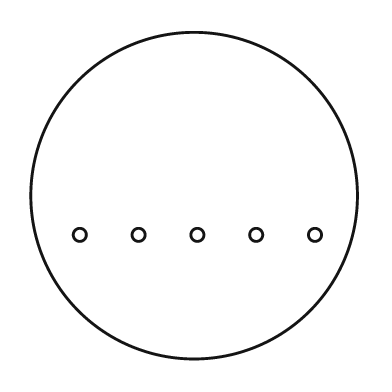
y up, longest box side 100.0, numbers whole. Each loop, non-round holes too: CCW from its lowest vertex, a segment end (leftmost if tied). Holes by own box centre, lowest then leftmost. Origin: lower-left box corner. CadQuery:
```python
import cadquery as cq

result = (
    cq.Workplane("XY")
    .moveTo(50.0, 50.0)
    .circle(50.0)
    .moveTo(15.0, 38.0)
    .circle(2.0)
    .moveTo(33.0, 38.0)
    .circle(2.0)
    .moveTo(51.0, 38.0)
    .circle(2.0)
    .moveTo(69.0, 38.0)
    .circle(2.0)
    .moveTo(87.0, 38.0)
    .circle(2.0)
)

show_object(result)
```